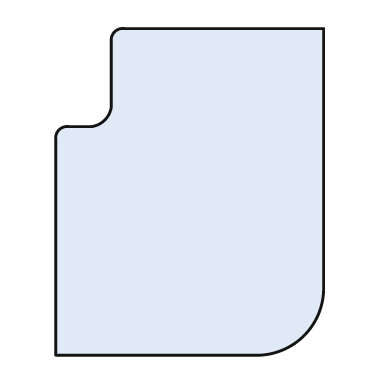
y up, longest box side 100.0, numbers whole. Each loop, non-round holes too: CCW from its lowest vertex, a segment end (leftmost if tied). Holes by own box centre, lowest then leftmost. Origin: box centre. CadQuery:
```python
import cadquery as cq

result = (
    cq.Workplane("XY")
    .moveTo(-41.0, -50.0)
    .lineTo(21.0, -50.0)
    .threePointArc((35.0, -44.0), (41.0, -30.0))
    .lineTo(41.0, 50.0)
    .lineTo(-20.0, 50.0)
    .threePointArc((-23.0, 49.0), (-24.0, 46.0))
    .lineTo(-24.0, 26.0)
    .threePointArc((-26.0, 22.0), (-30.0, 20.0))
    .lineTo(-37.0, 20.0)
    .threePointArc((-40.0, 19.0), (-41.0, 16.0))
    .close()
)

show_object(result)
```